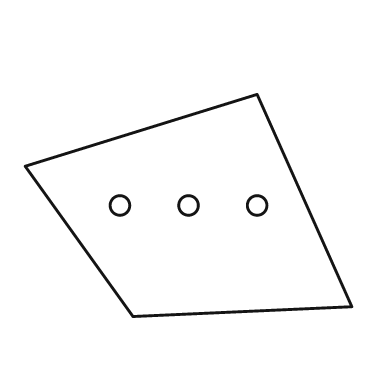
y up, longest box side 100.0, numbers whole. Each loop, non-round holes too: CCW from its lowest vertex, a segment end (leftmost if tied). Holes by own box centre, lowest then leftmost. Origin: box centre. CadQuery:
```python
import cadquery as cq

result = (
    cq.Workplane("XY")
    .moveTo(-17.0, -34.0)
    .lineTo(50.0, -31.0)
    .lineTo(21.0, 34.0)
    .lineTo(-50.0, 12.0)
    .close()
    .moveTo(-21.0, 0.0)
    .circle(3.0)
    .moveTo(0.0, 0.0)
    .circle(3.0)
    .moveTo(21.0, 0.0)
    .circle(3.0)
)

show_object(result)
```